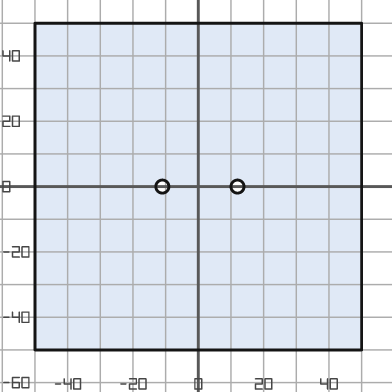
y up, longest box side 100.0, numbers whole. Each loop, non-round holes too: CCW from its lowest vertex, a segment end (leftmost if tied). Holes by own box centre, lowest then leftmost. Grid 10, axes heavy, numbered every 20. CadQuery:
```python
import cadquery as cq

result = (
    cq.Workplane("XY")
    .moveTo(-50.0, -50.0)
    .lineTo(50.0, -50.0)
    .lineTo(50.0, 50.0)
    .lineTo(-50.0, 50.0)
    .close()
    .moveTo(-11.0, 0.0)
    .circle(2.0)
    .moveTo(12.0, 0.0)
    .circle(2.0)
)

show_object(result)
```